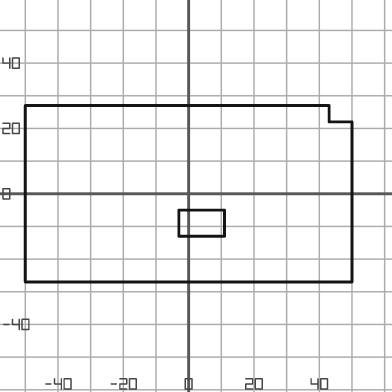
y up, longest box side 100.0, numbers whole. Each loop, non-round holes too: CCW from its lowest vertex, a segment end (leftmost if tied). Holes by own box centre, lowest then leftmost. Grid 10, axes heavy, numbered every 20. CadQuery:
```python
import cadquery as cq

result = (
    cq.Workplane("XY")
    .moveTo(-50.0, -27.0)
    .lineTo(50.0, -27.0)
    .lineTo(50.0, 22.0)
    .lineTo(43.0, 22.0)
    .lineTo(43.0, 27.0)
    .lineTo(-50.0, 27.0)
    .close()
    .moveTo(-3.0, -13.0)
    .lineTo(11.0, -13.0)
    .lineTo(11.0, -5.0)
    .lineTo(-3.0, -5.0)
    .close()
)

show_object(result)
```